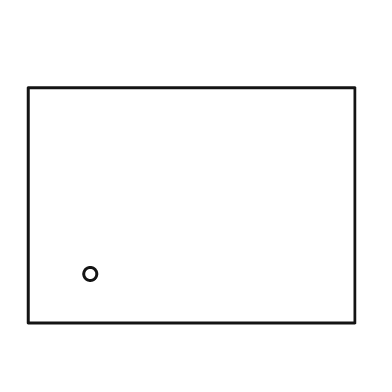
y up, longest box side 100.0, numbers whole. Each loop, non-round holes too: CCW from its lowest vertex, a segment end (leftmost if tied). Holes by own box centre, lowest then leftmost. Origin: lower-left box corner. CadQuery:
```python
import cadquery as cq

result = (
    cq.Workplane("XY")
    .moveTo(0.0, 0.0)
    .lineTo(100.0, 0.0)
    .lineTo(100.0, 72.0)
    .lineTo(0.0, 72.0)
    .close()
    .moveTo(19.0, 15.0)
    .circle(2.0)
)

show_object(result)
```